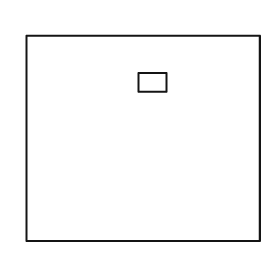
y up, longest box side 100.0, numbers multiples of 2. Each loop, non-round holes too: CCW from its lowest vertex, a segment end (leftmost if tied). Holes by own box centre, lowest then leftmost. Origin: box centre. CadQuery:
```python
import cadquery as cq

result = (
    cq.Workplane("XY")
    .moveTo(-50.0, -44.0)
    .lineTo(50.0, -44.0)
    .lineTo(50.0, 44.0)
    .lineTo(-50.0, 44.0)
    .close()
    .moveTo(-2.0, 20.0)
    .lineTo(10.0, 20.0)
    .lineTo(10.0, 28.0)
    .lineTo(-2.0, 28.0)
    .close()
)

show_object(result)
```